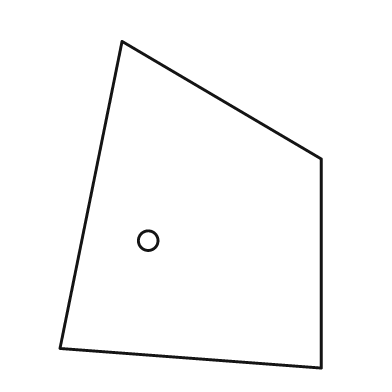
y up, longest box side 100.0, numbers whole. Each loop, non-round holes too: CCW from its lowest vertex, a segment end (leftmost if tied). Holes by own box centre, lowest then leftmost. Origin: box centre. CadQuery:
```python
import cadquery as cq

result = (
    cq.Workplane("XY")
    .moveTo(40.0, -50.0)
    .lineTo(40.0, 14.0)
    .lineTo(-21.0, 50.0)
    .lineTo(-40.0, -44.0)
    .close()
    .moveTo(-13.0, -11.0)
    .circle(3.0)
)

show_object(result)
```